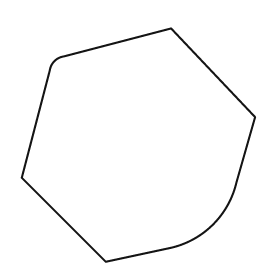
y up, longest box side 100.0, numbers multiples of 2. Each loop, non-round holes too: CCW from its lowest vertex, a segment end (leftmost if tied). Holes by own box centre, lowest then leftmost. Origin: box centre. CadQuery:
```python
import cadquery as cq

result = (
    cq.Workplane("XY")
    .moveTo(-14.0, -50.0)
    .lineTo(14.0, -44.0)
    .threePointArc((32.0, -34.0), (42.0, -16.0))
    .lineTo(50.0, 12.0)
    .lineTo(14.0, 50.0)
    .lineTo(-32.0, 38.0)
    .threePointArc((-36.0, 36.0), (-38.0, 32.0))
    .lineTo(-50.0, -14.0)
    .close()
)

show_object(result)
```